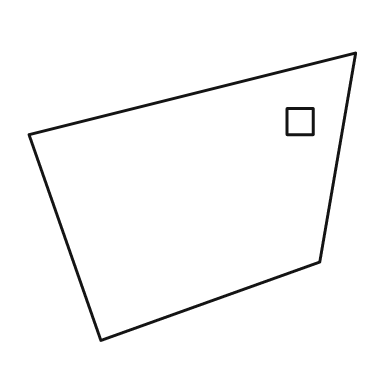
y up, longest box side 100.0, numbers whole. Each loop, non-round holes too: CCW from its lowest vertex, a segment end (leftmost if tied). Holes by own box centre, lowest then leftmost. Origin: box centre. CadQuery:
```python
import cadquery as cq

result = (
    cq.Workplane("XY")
    .moveTo(-28.0, -44.0)
    .lineTo(39.0, -20.0)
    .lineTo(50.0, 44.0)
    .lineTo(-50.0, 19.0)
    .close()
    .moveTo(29.0, 19.0)
    .lineTo(37.0, 19.0)
    .lineTo(37.0, 27.0)
    .lineTo(29.0, 27.0)
    .close()
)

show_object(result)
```